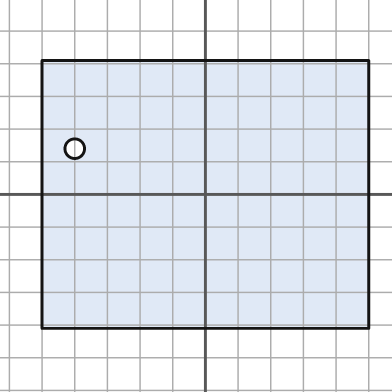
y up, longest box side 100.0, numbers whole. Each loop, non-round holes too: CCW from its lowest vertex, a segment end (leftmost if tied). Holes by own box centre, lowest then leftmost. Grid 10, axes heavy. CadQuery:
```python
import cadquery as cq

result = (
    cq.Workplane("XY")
    .moveTo(-50.0, -41.0)
    .lineTo(50.0, -41.0)
    .lineTo(50.0, 41.0)
    .lineTo(-50.0, 41.0)
    .close()
    .moveTo(-40.0, 14.0)
    .circle(3.0)
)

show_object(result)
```